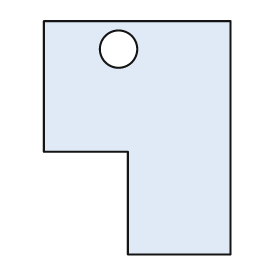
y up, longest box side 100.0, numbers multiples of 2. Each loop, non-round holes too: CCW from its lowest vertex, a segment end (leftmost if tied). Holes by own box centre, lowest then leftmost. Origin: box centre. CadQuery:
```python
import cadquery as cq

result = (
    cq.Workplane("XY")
    .moveTo(-4.0, -50.0)
    .lineTo(40.0, -50.0)
    .lineTo(40.0, 50.0)
    .lineTo(-40.0, 50.0)
    .lineTo(-40.0, -6.0)
    .lineTo(-4.0, -6.0)
    .close()
    .moveTo(-8.0, 38.0)
    .circle(8.0)
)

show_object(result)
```